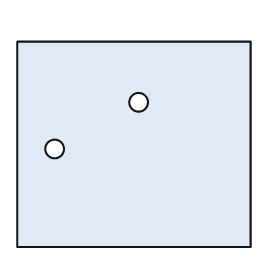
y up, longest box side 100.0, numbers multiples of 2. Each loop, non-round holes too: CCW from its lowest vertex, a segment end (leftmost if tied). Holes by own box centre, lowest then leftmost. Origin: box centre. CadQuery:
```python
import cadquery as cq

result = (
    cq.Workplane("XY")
    .moveTo(-50.0, -44.0)
    .lineTo(50.0, -44.0)
    .lineTo(50.0, 44.0)
    .lineTo(-50.0, 44.0)
    .close()
    .moveTo(-34.0, -2.0)
    .circle(4.0)
    .moveTo(2.0, 18.0)
    .circle(4.0)
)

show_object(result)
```